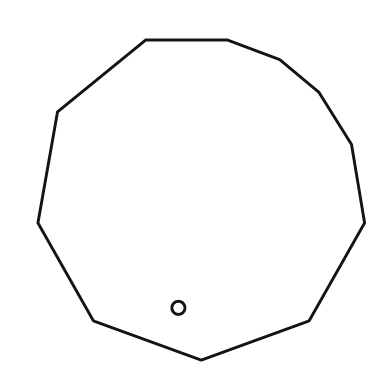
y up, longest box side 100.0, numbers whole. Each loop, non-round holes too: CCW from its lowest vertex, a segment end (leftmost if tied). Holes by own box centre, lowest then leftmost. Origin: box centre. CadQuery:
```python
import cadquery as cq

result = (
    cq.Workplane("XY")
    .moveTo(0.0, -49.0)
    .lineTo(33.0, -37.0)
    .lineTo(50.0, -7.0)
    .lineTo(46.0, 17.0)
    .lineTo(36.0, 33.0)
    .lineTo(24.0, 43.0)
    .lineTo(8.0, 49.0)
    .lineTo(-17.0, 49.0)
    .lineTo(-44.0, 27.0)
    .lineTo(-50.0, -7.0)
    .lineTo(-33.0, -37.0)
    .close()
    .moveTo(-7.0, -33.0)
    .circle(2.0)
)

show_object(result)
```